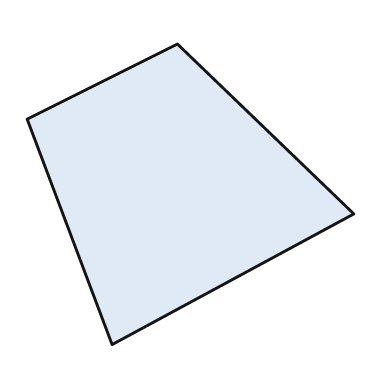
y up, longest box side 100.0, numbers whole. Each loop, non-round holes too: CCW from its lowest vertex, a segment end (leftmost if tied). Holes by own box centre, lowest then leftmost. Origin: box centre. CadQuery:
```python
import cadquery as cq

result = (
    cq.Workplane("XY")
    .moveTo(-24.0, -46.0)
    .lineTo(50.0, -6.0)
    .lineTo(-4.0, 46.0)
    .lineTo(-50.0, 23.0)
    .close()
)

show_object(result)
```